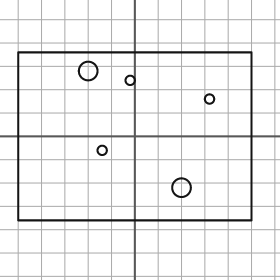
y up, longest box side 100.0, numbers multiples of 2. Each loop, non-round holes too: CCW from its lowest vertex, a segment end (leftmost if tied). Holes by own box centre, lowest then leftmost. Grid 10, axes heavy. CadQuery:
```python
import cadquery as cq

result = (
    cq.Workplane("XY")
    .moveTo(-50.0, -36.0)
    .lineTo(50.0, -36.0)
    .lineTo(50.0, 36.0)
    .lineTo(-50.0, 36.0)
    .close()
    .moveTo(20.0, -22.0)
    .circle(4.0)
    .moveTo(-14.0, -6.0)
    .circle(2.0)
    .moveTo(32.0, 16.0)
    .circle(2.0)
    .moveTo(-2.0, 24.0)
    .circle(2.0)
    .moveTo(-20.0, 28.0)
    .circle(4.0)
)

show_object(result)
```